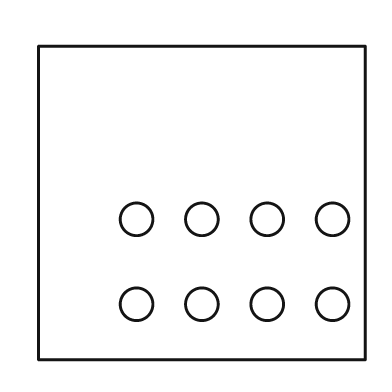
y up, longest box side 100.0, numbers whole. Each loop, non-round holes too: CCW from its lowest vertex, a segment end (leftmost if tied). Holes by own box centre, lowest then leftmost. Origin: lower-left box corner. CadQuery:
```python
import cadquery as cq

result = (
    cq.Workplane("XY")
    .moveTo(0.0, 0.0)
    .lineTo(100.0, 0.0)
    .lineTo(100.0, 96.0)
    .lineTo(0.0, 96.0)
    .close()
    .moveTo(30.0, 17.0)
    .circle(5.0)
    .moveTo(50.0, 17.0)
    .circle(5.0)
    .moveTo(70.0, 17.0)
    .circle(5.0)
    .moveTo(90.0, 17.0)
    .circle(5.0)
    .moveTo(30.0, 43.0)
    .circle(5.0)
    .moveTo(50.0, 43.0)
    .circle(5.0)
    .moveTo(70.0, 43.0)
    .circle(5.0)
    .moveTo(90.0, 43.0)
    .circle(5.0)
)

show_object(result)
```